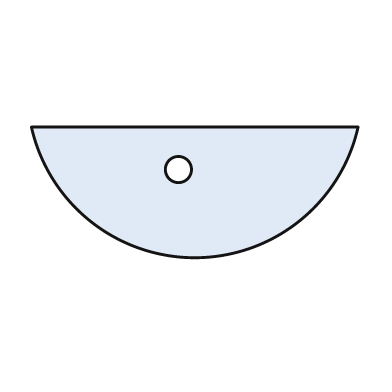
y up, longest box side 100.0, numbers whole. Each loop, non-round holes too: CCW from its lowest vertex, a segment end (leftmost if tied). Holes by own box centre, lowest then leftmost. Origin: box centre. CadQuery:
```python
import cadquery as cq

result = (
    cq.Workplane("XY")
    .moveTo(-50.0, 20.0)
    .threePointArc((0.0, -20.0), (50.0, 20.0))
    .close()
    .moveTo(-5.0, 7.0)
    .circle(4.0)
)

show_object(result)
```